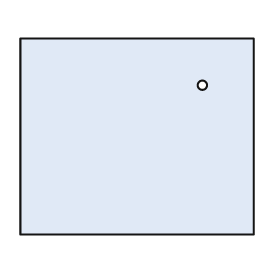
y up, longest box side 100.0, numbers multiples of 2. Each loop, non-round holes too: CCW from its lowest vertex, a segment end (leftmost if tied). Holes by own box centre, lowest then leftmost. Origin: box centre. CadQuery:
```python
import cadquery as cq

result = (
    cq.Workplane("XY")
    .moveTo(-50.0, -42.0)
    .lineTo(50.0, -42.0)
    .lineTo(50.0, 42.0)
    .lineTo(-50.0, 42.0)
    .close()
    .moveTo(28.0, 22.0)
    .circle(2.0)
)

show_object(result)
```